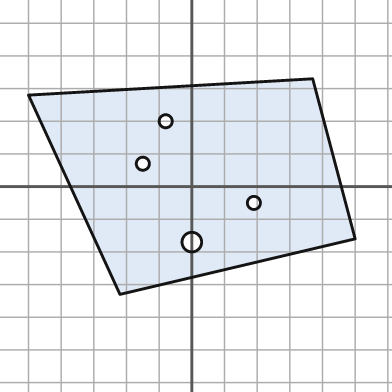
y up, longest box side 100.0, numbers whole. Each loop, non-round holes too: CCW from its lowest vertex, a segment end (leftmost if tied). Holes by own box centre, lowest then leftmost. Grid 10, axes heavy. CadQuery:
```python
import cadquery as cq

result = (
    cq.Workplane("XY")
    .moveTo(-22.0, -33.0)
    .lineTo(50.0, -16.0)
    .lineTo(37.0, 33.0)
    .lineTo(-50.0, 28.0)
    .close()
    .moveTo(0.0, -17.0)
    .circle(3.0)
    .moveTo(19.0, -5.0)
    .circle(2.0)
    .moveTo(-15.0, 7.0)
    .circle(2.0)
    .moveTo(-8.0, 20.0)
    .circle(2.0)
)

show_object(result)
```